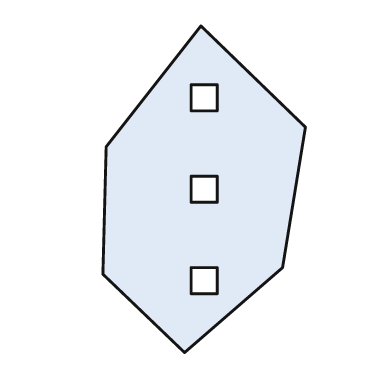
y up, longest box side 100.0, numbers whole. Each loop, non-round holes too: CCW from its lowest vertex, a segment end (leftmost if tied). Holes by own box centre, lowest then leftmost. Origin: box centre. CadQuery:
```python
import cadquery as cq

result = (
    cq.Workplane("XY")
    .moveTo(-6.0, -50.0)
    .lineTo(24.0, -24.0)
    .lineTo(31.0, 19.0)
    .lineTo(-1.0, 50.0)
    .lineTo(-30.0, 13.0)
    .lineTo(-31.0, -26.0)
    .close()
    .moveTo(-4.0, -32.0)
    .lineTo(4.0, -32.0)
    .lineTo(4.0, -24.0)
    .lineTo(-4.0, -24.0)
    .close()
    .moveTo(-4.0, -4.0)
    .lineTo(4.0, -4.0)
    .lineTo(4.0, 4.0)
    .lineTo(-4.0, 4.0)
    .close()
    .moveTo(-4.0, 24.0)
    .lineTo(4.0, 24.0)
    .lineTo(4.0, 32.0)
    .lineTo(-4.0, 32.0)
    .close()
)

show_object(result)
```